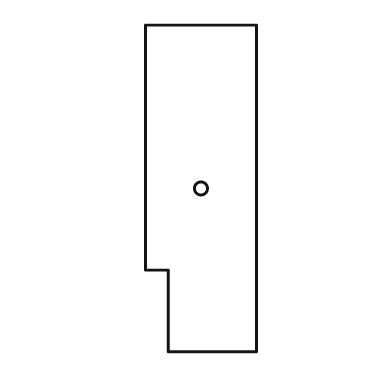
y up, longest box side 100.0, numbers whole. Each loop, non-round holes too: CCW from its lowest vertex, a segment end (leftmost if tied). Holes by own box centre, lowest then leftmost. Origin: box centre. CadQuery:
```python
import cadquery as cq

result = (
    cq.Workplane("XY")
    .moveTo(-10.0, -50.0)
    .lineTo(17.0, -50.0)
    .lineTo(17.0, 50.0)
    .lineTo(-17.0, 50.0)
    .lineTo(-17.0, -25.0)
    .lineTo(-10.0, -25.0)
    .close()
    .moveTo(0.0, 0.0)
    .circle(2.0)
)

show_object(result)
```